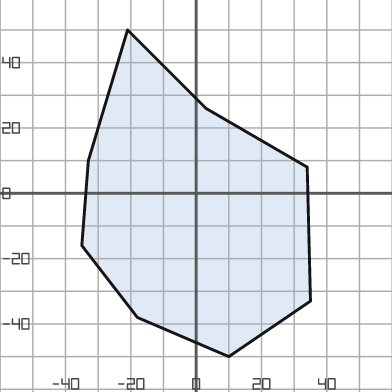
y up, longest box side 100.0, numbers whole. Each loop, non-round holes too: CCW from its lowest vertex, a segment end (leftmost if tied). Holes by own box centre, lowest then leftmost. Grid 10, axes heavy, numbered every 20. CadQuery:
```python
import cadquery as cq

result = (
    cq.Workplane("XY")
    .moveTo(10.0, -50.0)
    .lineTo(35.0, -33.0)
    .lineTo(34.0, 8.0)
    .lineTo(3.0, 26.0)
    .lineTo(-21.0, 50.0)
    .lineTo(-33.0, 10.0)
    .lineTo(-35.0, -16.0)
    .lineTo(-18.0, -38.0)
    .close()
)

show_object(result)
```